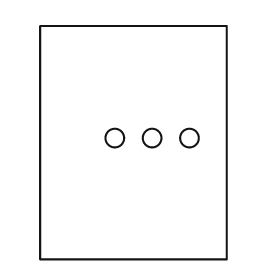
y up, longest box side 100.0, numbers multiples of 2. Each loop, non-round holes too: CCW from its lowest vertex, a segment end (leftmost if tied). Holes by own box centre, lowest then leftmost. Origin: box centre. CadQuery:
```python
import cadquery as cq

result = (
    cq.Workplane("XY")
    .moveTo(-40.0, -50.0)
    .lineTo(40.0, -50.0)
    .lineTo(40.0, 50.0)
    .lineTo(-40.0, 50.0)
    .close()
    .moveTo(-8.0, 2.0)
    .circle(4.0)
    .moveTo(8.0, 2.0)
    .circle(4.0)
    .moveTo(24.0, 2.0)
    .circle(4.0)
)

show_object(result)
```